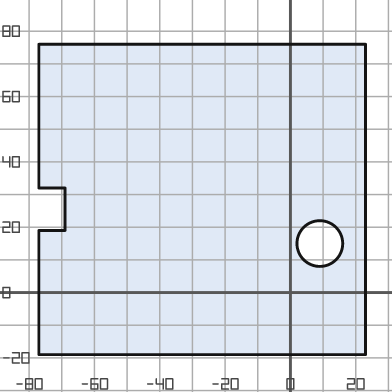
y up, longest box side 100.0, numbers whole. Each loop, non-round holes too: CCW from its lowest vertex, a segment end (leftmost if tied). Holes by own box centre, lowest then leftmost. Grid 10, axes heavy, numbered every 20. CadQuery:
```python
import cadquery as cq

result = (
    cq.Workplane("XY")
    .moveTo(-77.0, -19.0)
    .lineTo(23.0, -19.0)
    .lineTo(23.0, 76.0)
    .lineTo(-77.0, 76.0)
    .lineTo(-77.0, 32.0)
    .lineTo(-69.0, 32.0)
    .lineTo(-69.0, 19.0)
    .lineTo(-77.0, 19.0)
    .close()
    .moveTo(9.0, 15.0)
    .circle(7.0)
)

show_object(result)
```